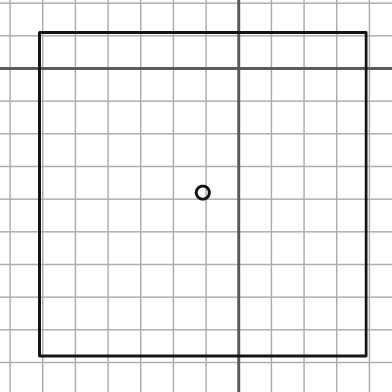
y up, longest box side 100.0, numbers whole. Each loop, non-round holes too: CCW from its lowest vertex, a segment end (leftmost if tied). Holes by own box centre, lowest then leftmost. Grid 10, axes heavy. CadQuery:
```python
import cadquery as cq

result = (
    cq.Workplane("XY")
    .moveTo(-61.0, -88.0)
    .lineTo(39.0, -88.0)
    .lineTo(39.0, 11.0)
    .lineTo(-61.0, 11.0)
    .close()
    .moveTo(-11.0, -38.0)
    .circle(2.0)
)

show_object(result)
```